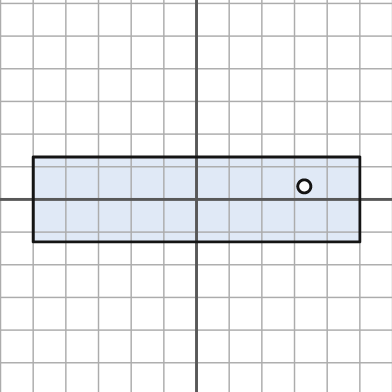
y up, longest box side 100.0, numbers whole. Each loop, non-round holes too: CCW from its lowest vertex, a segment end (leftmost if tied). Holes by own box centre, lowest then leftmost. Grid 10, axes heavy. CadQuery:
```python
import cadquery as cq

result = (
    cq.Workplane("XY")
    .moveTo(-50.0, -13.0)
    .lineTo(50.0, -13.0)
    .lineTo(50.0, 13.0)
    .lineTo(-50.0, 13.0)
    .close()
    .moveTo(33.0, 4.0)
    .circle(2.0)
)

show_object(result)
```